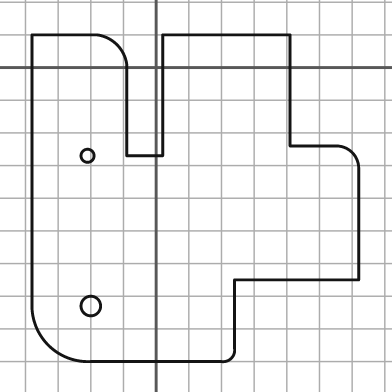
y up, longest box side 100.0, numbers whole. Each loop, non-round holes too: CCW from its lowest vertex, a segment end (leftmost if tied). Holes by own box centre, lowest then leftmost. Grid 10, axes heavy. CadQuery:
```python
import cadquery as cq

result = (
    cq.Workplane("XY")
    .moveTo(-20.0, -90.0)
    .lineTo(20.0, -90.0)
    .threePointArc((23.0, -89.0), (24.0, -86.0))
    .lineTo(24.0, -65.0)
    .lineTo(62.0, -65.0)
    .lineTo(62.0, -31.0)
    .threePointArc((60.0, -26.0), (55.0, -24.0))
    .lineTo(41.0, -24.0)
    .lineTo(41.0, 10.0)
    .lineTo(2.0, 10.0)
    .lineTo(2.0, -27.0)
    .lineTo(-9.0, -27.0)
    .lineTo(-9.0, 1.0)
    .threePointArc((-12.0, 7.0), (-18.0, 10.0))
    .lineTo(-38.0, 10.0)
    .lineTo(-38.0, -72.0)
    .threePointArc((-33.0, -85.0), (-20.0, -90.0))
    .close()
    .moveTo(-20.0, -73.0)
    .circle(3.0)
    .moveTo(-21.0, -27.0)
    .circle(2.0)
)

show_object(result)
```